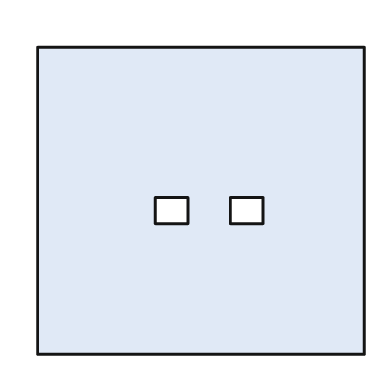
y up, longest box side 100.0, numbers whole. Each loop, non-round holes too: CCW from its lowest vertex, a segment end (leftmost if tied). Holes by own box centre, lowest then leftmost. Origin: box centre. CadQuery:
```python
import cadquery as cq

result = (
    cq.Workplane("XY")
    .moveTo(-50.0, -47.0)
    .lineTo(50.0, -47.0)
    .lineTo(50.0, 47.0)
    .lineTo(-50.0, 47.0)
    .close()
    .moveTo(-14.0, -7.0)
    .lineTo(-4.0, -7.0)
    .lineTo(-4.0, 1.0)
    .lineTo(-14.0, 1.0)
    .close()
    .moveTo(9.0, -7.0)
    .lineTo(19.0, -7.0)
    .lineTo(19.0, 1.0)
    .lineTo(9.0, 1.0)
    .close()
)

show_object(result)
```